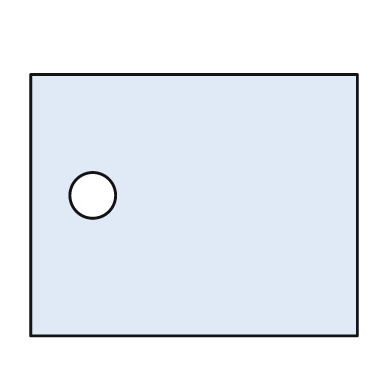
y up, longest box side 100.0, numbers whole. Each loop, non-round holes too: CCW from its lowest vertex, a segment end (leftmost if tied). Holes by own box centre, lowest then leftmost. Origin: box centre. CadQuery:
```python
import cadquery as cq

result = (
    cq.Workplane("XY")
    .moveTo(-50.0, -40.0)
    .lineTo(50.0, -40.0)
    .lineTo(50.0, 40.0)
    .lineTo(-50.0, 40.0)
    .close()
    .moveTo(-31.0, 3.0)
    .circle(7.0)
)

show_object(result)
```